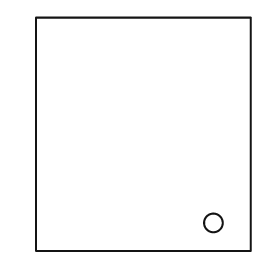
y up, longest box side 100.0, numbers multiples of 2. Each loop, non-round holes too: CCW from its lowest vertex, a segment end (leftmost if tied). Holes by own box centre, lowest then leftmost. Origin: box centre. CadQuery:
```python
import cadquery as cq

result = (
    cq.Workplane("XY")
    .moveTo(-46.0, -50.0)
    .lineTo(46.0, -50.0)
    .lineTo(46.0, 50.0)
    .lineTo(-46.0, 50.0)
    .close()
    .moveTo(30.0, -38.0)
    .circle(4.0)
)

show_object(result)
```